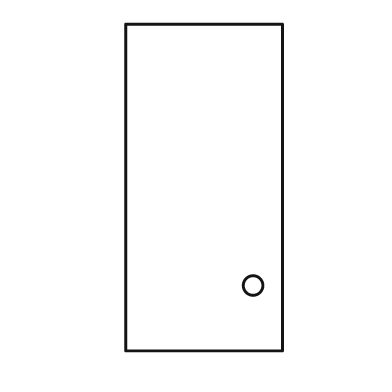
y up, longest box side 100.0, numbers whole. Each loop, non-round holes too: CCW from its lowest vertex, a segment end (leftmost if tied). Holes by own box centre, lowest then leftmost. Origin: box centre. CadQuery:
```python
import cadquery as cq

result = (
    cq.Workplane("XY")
    .moveTo(-24.0, -50.0)
    .lineTo(24.0, -50.0)
    .lineTo(24.0, 50.0)
    .lineTo(-24.0, 50.0)
    .close()
    .moveTo(15.0, -30.0)
    .circle(3.0)
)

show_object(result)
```